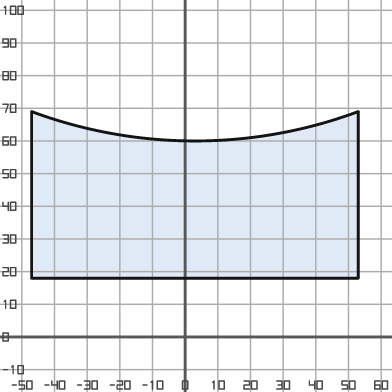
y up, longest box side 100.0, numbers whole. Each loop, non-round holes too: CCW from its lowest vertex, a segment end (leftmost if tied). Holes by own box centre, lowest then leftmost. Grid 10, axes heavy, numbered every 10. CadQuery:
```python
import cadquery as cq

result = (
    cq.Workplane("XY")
    .moveTo(-47.0, 18.0)
    .lineTo(53.0, 18.0)
    .lineTo(53.0, 69.0)
    .threePointArc((3.0, 60.0), (-47.0, 69.0))
    .close()
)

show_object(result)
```